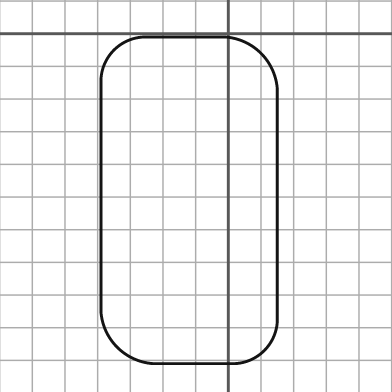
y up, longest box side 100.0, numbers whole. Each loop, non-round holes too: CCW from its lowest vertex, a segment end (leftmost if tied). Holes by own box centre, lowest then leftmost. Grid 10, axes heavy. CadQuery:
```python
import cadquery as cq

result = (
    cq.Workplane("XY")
    .moveTo(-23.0, -101.0)
    .lineTo(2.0, -101.0)
    .threePointArc((11.0, -97.0), (15.0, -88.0))
    .lineTo(15.0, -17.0)
    .threePointArc((10.0, -6.0), (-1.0, -1.0))
    .lineTo(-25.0, -1.0)
    .threePointArc((-35.0, -5.0), (-39.0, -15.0))
    .lineTo(-39.0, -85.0)
    .threePointArc((-34.0, -96.0), (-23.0, -101.0))
    .close()
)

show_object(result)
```